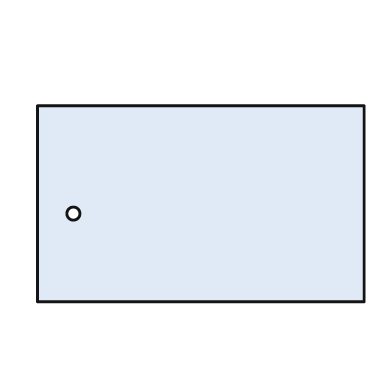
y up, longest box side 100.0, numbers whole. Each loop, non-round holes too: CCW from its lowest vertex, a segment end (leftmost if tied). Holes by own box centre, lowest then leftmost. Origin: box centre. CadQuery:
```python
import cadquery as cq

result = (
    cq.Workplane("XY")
    .moveTo(-50.0, -30.0)
    .lineTo(50.0, -30.0)
    .lineTo(50.0, 30.0)
    .lineTo(-50.0, 30.0)
    .close()
    .moveTo(-39.0, -3.0)
    .circle(2.0)
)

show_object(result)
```